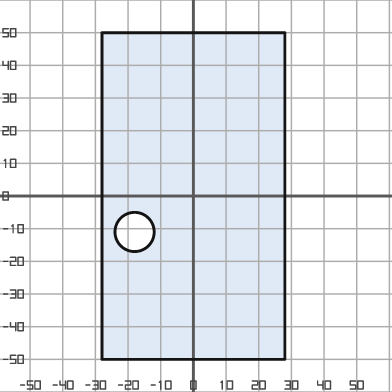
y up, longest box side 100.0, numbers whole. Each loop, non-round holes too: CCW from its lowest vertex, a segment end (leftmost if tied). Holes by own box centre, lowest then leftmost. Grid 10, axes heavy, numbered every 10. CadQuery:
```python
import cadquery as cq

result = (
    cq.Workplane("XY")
    .moveTo(-28.0, -50.0)
    .lineTo(28.0, -50.0)
    .lineTo(28.0, 50.0)
    .lineTo(-28.0, 50.0)
    .close()
    .moveTo(-18.0, -11.0)
    .circle(6.0)
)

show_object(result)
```